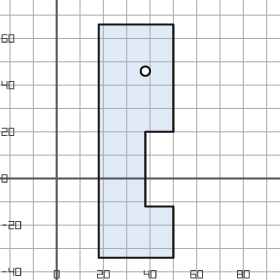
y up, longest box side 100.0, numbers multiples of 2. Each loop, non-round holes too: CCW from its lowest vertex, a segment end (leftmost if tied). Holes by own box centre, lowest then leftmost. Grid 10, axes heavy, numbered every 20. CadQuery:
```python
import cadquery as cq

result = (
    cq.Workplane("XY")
    .moveTo(18.0, -34.0)
    .lineTo(50.0, -34.0)
    .lineTo(50.0, -12.0)
    .lineTo(38.0, -12.0)
    .lineTo(38.0, 20.0)
    .lineTo(50.0, 20.0)
    .lineTo(50.0, 66.0)
    .lineTo(18.0, 66.0)
    .close()
    .moveTo(38.0, 46.0)
    .circle(2.0)
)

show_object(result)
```